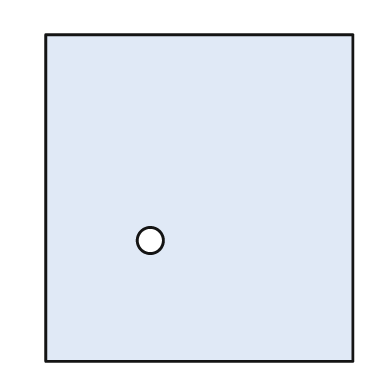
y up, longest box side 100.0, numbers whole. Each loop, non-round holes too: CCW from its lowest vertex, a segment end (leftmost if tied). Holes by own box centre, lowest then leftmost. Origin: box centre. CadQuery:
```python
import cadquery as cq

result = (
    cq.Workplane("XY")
    .moveTo(-47.0, -50.0)
    .lineTo(47.0, -50.0)
    .lineTo(47.0, 50.0)
    .lineTo(-47.0, 50.0)
    .close()
    .moveTo(-15.0, -13.0)
    .circle(4.0)
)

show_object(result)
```